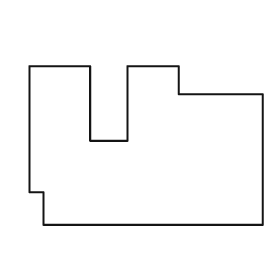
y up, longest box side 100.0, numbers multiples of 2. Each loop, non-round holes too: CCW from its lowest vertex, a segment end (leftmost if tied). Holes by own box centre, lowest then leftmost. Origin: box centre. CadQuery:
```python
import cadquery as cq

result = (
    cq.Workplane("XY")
    .moveTo(-44.0, -34.0)
    .lineTo(50.0, -34.0)
    .lineTo(50.0, 22.0)
    .lineTo(14.0, 22.0)
    .lineTo(14.0, 34.0)
    .lineTo(-8.0, 34.0)
    .lineTo(-8.0, 2.0)
    .lineTo(-24.0, 2.0)
    .lineTo(-24.0, 34.0)
    .lineTo(-50.0, 34.0)
    .lineTo(-50.0, -20.0)
    .lineTo(-44.0, -20.0)
    .close()
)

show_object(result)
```